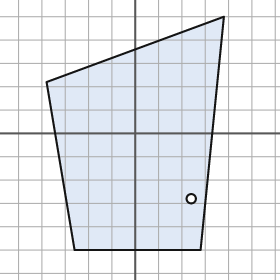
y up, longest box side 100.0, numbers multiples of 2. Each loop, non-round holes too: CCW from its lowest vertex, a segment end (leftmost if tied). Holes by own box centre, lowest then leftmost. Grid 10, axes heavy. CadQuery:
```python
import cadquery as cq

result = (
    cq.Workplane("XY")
    .moveTo(-26.0, -50.0)
    .lineTo(28.0, -50.0)
    .lineTo(38.0, 50.0)
    .lineTo(-38.0, 22.0)
    .close()
    .moveTo(24.0, -28.0)
    .circle(2.0)
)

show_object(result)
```